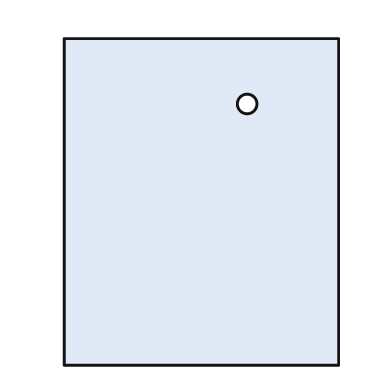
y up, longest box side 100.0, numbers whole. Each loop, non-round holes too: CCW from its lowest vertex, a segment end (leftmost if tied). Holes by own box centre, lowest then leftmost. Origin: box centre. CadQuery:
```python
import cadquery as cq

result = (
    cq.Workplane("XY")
    .moveTo(-42.0, -50.0)
    .lineTo(42.0, -50.0)
    .lineTo(42.0, 50.0)
    .lineTo(-42.0, 50.0)
    .close()
    .moveTo(14.0, 30.0)
    .circle(3.0)
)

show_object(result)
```